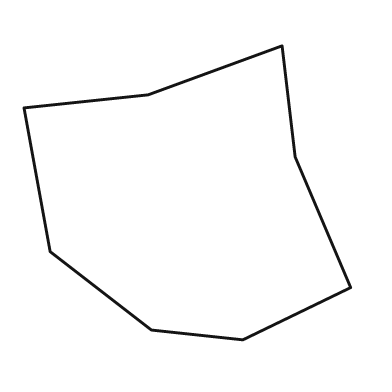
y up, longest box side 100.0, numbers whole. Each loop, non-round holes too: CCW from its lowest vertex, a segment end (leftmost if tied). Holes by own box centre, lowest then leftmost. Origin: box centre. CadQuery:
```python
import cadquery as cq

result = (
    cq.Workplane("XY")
    .moveTo(17.0, -45.0)
    .lineTo(50.0, -29.0)
    .lineTo(33.0, 11.0)
    .lineTo(29.0, 45.0)
    .lineTo(-12.0, 30.0)
    .lineTo(-50.0, 26.0)
    .lineTo(-42.0, -18.0)
    .lineTo(-11.0, -42.0)
    .close()
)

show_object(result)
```